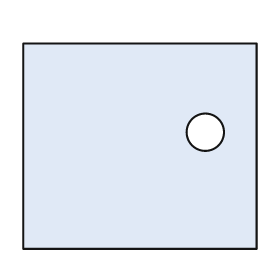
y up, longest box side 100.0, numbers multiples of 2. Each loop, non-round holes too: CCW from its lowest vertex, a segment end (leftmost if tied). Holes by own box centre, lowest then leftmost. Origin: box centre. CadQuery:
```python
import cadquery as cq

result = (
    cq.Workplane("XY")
    .moveTo(-50.0, -44.0)
    .lineTo(50.0, -44.0)
    .lineTo(50.0, 44.0)
    .lineTo(-50.0, 44.0)
    .close()
    .moveTo(28.0, 6.0)
    .circle(8.0)
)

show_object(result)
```